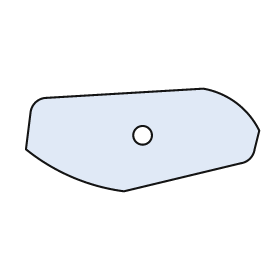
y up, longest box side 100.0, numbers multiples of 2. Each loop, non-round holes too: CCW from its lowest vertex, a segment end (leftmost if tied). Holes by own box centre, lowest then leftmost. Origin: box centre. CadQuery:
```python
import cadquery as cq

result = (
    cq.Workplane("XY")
    .moveTo(-8.0, -22.0)
    .lineTo(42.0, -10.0)
    .threePointArc((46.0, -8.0), (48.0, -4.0))
    .lineTo(50.0, 4.0)
    .threePointArc((40.0, 16.0), (26.0, 22.0))
    .lineTo(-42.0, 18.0)
    .threePointArc((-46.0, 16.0), (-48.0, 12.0))
    .lineTo(-50.0, -4.0)
    .threePointArc((-30.0, -16.0), (-8.0, -22.0))
    .close()
    .moveTo(0.0, 2.0)
    .circle(4.0)
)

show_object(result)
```